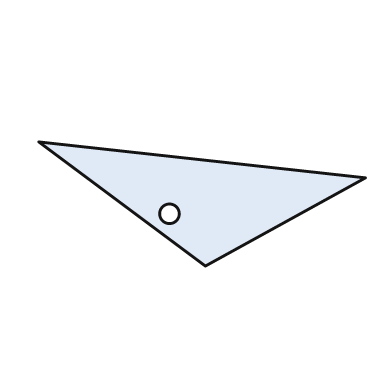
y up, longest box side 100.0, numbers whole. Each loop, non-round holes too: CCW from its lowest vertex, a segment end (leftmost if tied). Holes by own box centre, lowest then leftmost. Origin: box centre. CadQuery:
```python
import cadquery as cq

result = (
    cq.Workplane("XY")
    .moveTo(1.0, -19.0)
    .lineTo(50.0, 8.0)
    .lineTo(-50.0, 19.0)
    .close()
    .moveTo(-10.0, -3.0)
    .circle(3.0)
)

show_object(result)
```